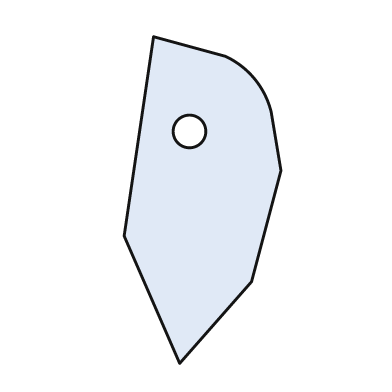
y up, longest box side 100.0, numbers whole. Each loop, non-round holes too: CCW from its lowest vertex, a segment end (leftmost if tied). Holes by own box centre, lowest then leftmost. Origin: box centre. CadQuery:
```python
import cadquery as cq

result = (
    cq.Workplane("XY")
    .moveTo(-7.0, -50.0)
    .lineTo(15.0, -25.0)
    .lineTo(24.0, 9.0)
    .lineTo(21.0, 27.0)
    .threePointArc((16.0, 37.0), (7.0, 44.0))
    .lineTo(-15.0, 50.0)
    .lineTo(-24.0, -11.0)
    .close()
    .moveTo(-4.0, 21.0)
    .circle(5.0)
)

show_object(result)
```